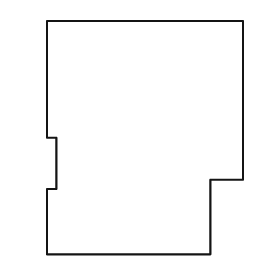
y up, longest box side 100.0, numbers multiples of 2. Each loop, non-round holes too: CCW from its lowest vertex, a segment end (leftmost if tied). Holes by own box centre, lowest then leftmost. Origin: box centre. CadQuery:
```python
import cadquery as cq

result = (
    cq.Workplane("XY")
    .moveTo(-42.0, -50.0)
    .lineTo(28.0, -50.0)
    .lineTo(28.0, -18.0)
    .lineTo(42.0, -18.0)
    .lineTo(42.0, 50.0)
    .lineTo(-42.0, 50.0)
    .lineTo(-42.0, 0.0)
    .lineTo(-38.0, 0.0)
    .lineTo(-38.0, -22.0)
    .lineTo(-42.0, -22.0)
    .close()
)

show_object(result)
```